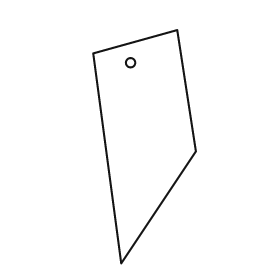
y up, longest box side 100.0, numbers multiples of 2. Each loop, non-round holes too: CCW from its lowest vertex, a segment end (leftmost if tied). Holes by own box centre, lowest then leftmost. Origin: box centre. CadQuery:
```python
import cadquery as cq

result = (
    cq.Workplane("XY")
    .moveTo(-10.0, -50.0)
    .lineTo(22.0, -2.0)
    .lineTo(14.0, 50.0)
    .lineTo(-22.0, 40.0)
    .close()
    .moveTo(-6.0, 36.0)
    .circle(2.0)
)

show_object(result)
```